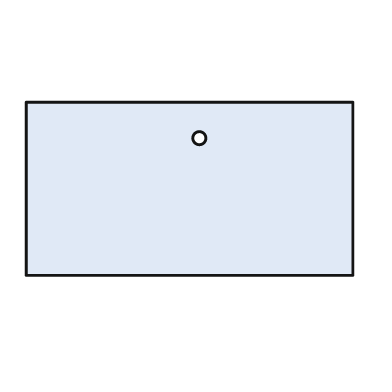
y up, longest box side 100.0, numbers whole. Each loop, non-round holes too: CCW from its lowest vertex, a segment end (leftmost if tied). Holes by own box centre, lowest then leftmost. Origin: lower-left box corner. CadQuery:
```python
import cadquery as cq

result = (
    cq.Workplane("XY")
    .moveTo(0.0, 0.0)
    .lineTo(100.0, 0.0)
    .lineTo(100.0, 53.0)
    .lineTo(0.0, 53.0)
    .close()
    .moveTo(53.0, 42.0)
    .circle(2.0)
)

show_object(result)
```